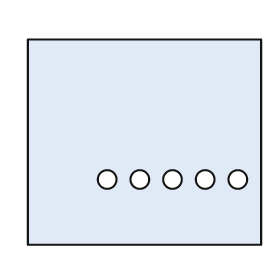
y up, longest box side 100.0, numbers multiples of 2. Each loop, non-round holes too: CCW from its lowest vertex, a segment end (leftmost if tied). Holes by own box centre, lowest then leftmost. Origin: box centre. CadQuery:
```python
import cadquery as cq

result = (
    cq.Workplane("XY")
    .moveTo(-50.0, -44.0)
    .lineTo(50.0, -44.0)
    .lineTo(50.0, 44.0)
    .lineTo(-50.0, 44.0)
    .close()
    .moveTo(-16.0, -16.0)
    .circle(4.0)
    .moveTo(-2.0, -16.0)
    .circle(4.0)
    .moveTo(12.0, -16.0)
    .circle(4.0)
    .moveTo(26.0, -16.0)
    .circle(4.0)
    .moveTo(40.0, -16.0)
    .circle(4.0)
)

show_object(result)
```